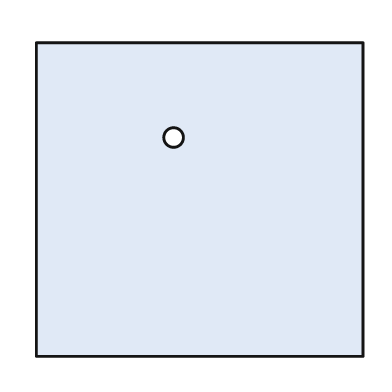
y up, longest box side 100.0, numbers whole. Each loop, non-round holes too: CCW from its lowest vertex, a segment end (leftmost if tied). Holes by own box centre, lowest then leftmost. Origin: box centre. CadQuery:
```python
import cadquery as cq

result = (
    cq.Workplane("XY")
    .moveTo(-50.0, -48.0)
    .lineTo(50.0, -48.0)
    .lineTo(50.0, 48.0)
    .lineTo(-50.0, 48.0)
    .close()
    .moveTo(-8.0, 19.0)
    .circle(3.0)
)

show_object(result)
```